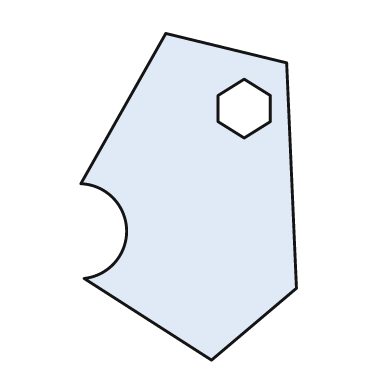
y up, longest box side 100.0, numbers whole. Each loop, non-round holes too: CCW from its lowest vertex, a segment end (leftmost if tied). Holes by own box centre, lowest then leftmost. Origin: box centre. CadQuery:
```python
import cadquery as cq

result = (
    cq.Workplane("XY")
    .moveTo(7.0, -50.0)
    .lineTo(33.0, -28.0)
    .lineTo(30.0, 41.0)
    .lineTo(-7.0, 50.0)
    .lineTo(-33.0, 4.0)
    .threePointArc((-19.0, -10.0), (-32.0, -25.0))
    .close()
    .moveTo(17.0, 18.0)
    .lineTo(25.0, 23.0)
    .lineTo(25.0, 31.0)
    .lineTo(17.0, 36.0)
    .lineTo(9.0, 31.0)
    .lineTo(9.0, 23.0)
    .close()
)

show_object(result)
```